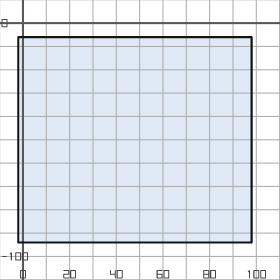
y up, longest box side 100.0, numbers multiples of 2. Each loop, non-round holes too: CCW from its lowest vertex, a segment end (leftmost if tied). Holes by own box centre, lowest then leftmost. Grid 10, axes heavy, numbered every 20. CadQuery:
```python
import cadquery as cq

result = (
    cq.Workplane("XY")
    .moveTo(-2.0, -94.0)
    .lineTo(98.0, -94.0)
    .lineTo(98.0, -6.0)
    .lineTo(-2.0, -6.0)
    .close()
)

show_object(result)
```